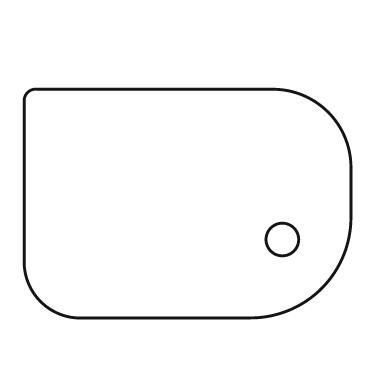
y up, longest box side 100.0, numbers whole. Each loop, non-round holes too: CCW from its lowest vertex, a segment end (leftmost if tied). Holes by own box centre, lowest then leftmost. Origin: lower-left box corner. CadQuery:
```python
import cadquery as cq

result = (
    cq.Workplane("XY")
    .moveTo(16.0, 0.0)
    .lineTo(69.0, 0.0)
    .threePointArc((91.0, 9.0), (100.0, 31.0))
    .lineTo(100.0, 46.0)
    .threePointArc((93.0, 63.0), (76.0, 70.0))
    .lineTo(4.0, 70.0)
    .threePointArc((1.0, 69.0), (0.0, 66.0))
    .lineTo(0.0, 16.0)
    .threePointArc((5.0, 5.0), (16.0, 0.0))
    .close()
    .moveTo(79.0, 24.0)
    .circle(5.0)
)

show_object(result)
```